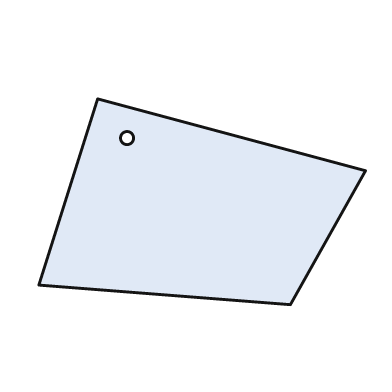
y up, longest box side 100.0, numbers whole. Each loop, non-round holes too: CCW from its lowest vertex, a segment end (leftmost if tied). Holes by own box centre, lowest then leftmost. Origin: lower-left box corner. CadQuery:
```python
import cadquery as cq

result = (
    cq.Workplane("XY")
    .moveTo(77.0, 0.0)
    .lineTo(100.0, 41.0)
    .lineTo(18.0, 63.0)
    .lineTo(0.0, 6.0)
    .close()
    .moveTo(27.0, 51.0)
    .circle(2.0)
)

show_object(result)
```